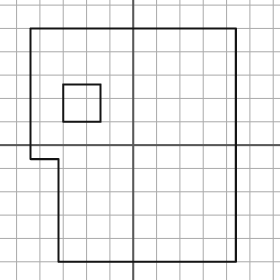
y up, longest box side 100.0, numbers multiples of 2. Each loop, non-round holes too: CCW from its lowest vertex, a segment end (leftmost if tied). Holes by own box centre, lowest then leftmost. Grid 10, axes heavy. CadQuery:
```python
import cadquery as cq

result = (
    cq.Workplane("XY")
    .moveTo(-32.0, -50.0)
    .lineTo(44.0, -50.0)
    .lineTo(44.0, 50.0)
    .lineTo(-44.0, 50.0)
    .lineTo(-44.0, -6.0)
    .lineTo(-32.0, -6.0)
    .close()
    .moveTo(-30.0, 10.0)
    .lineTo(-14.0, 10.0)
    .lineTo(-14.0, 26.0)
    .lineTo(-30.0, 26.0)
    .close()
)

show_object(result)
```